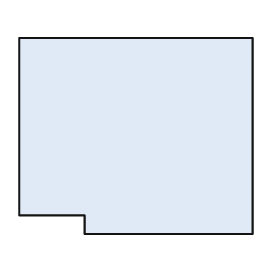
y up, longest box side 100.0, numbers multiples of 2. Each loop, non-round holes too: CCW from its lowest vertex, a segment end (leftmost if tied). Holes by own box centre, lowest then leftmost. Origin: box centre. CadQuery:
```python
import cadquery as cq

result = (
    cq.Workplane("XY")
    .moveTo(-22.0, -42.0)
    .lineTo(50.0, -42.0)
    .lineTo(50.0, 42.0)
    .lineTo(-50.0, 42.0)
    .lineTo(-50.0, -34.0)
    .lineTo(-22.0, -34.0)
    .close()
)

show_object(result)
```